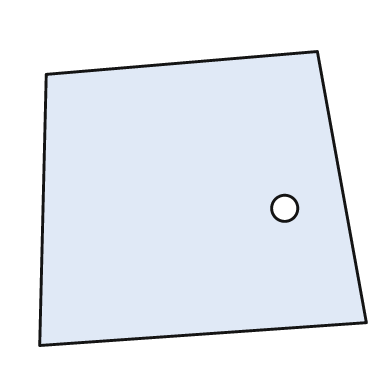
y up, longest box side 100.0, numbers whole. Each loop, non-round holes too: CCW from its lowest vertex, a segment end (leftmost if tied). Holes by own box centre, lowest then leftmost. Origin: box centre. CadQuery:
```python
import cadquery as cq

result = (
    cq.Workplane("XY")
    .moveTo(-50.0, -45.0)
    .lineTo(50.0, -38.0)
    .lineTo(35.0, 45.0)
    .lineTo(-48.0, 38.0)
    .close()
    .moveTo(25.0, -3.0)
    .circle(4.0)
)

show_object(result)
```